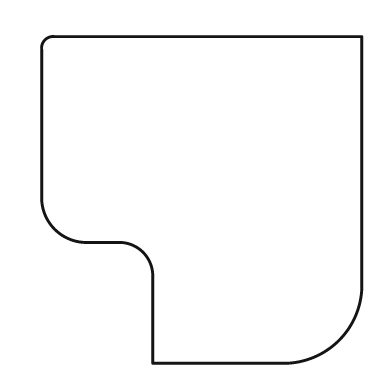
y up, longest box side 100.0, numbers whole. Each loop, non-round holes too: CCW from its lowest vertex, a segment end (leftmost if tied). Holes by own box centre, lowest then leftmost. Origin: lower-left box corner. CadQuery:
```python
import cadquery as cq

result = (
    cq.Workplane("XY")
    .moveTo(34.0, 0.0)
    .lineTo(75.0, 0.0)
    .threePointArc((91.0, 7.0), (98.0, 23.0))
    .lineTo(98.0, 100.0)
    .lineTo(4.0, 100.0)
    .threePointArc((1.0, 99.0), (0.0, 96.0))
    .lineTo(0.0, 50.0)
    .threePointArc((4.0, 41.0), (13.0, 37.0))
    .lineTo(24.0, 37.0)
    .threePointArc((31.0, 34.0), (34.0, 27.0))
    .close()
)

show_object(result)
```